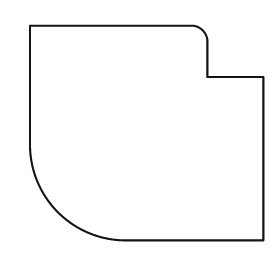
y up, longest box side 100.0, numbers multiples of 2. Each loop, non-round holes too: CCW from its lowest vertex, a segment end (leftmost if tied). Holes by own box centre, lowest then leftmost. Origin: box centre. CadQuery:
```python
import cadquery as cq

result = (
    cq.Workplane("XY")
    .moveTo(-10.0, -46.0)
    .lineTo(50.0, -46.0)
    .lineTo(50.0, 24.0)
    .lineTo(26.0, 24.0)
    .lineTo(26.0, 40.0)
    .threePointArc((24.0, 44.0), (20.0, 46.0))
    .lineTo(-50.0, 46.0)
    .lineTo(-50.0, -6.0)
    .threePointArc((-38.0, -34.0), (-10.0, -46.0))
    .close()
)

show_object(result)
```